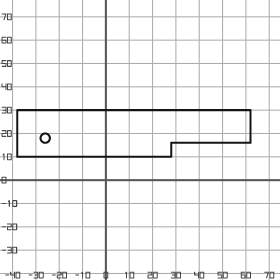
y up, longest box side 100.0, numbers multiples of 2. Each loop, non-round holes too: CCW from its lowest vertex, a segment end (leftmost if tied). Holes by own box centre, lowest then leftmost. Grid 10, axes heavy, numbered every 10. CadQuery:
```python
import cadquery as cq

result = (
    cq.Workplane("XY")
    .moveTo(-38.0, 10.0)
    .lineTo(28.0, 10.0)
    .lineTo(28.0, 16.0)
    .lineTo(62.0, 16.0)
    .lineTo(62.0, 30.0)
    .lineTo(-38.0, 30.0)
    .close()
    .moveTo(-26.0, 18.0)
    .circle(2.0)
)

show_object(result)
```